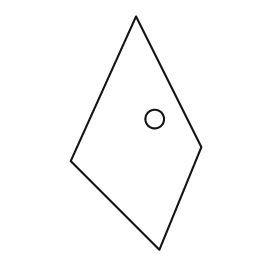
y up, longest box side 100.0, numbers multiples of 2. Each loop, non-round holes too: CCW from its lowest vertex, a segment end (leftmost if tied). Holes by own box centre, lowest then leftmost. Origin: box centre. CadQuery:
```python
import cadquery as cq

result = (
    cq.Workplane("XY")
    .moveTo(10.0, -50.0)
    .lineTo(28.0, -6.0)
    .lineTo(0.0, 50.0)
    .lineTo(-28.0, -12.0)
    .close()
    .moveTo(8.0, 6.0)
    .circle(4.0)
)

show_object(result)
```